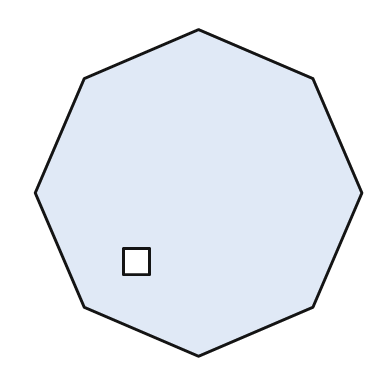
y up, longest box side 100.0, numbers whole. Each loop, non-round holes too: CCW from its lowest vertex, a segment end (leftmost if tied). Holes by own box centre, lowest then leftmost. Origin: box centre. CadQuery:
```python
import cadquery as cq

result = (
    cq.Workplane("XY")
    .moveTo(0.0, -50.0)
    .lineTo(35.0, -35.0)
    .lineTo(50.0, 0.0)
    .lineTo(35.0, 35.0)
    .lineTo(0.0, 50.0)
    .lineTo(-35.0, 35.0)
    .lineTo(-50.0, 0.0)
    .lineTo(-35.0, -35.0)
    .close()
    .moveTo(-23.0, -25.0)
    .lineTo(-15.0, -25.0)
    .lineTo(-15.0, -17.0)
    .lineTo(-23.0, -17.0)
    .close()
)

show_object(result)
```